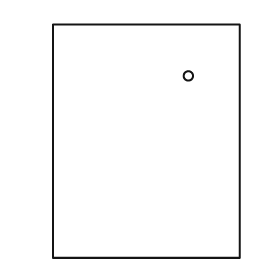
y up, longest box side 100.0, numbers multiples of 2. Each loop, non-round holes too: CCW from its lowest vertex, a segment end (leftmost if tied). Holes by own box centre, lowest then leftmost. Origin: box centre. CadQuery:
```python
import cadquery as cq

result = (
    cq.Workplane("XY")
    .moveTo(-40.0, -50.0)
    .lineTo(40.0, -50.0)
    .lineTo(40.0, 50.0)
    .lineTo(-40.0, 50.0)
    .close()
    .moveTo(18.0, 28.0)
    .circle(2.0)
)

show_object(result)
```